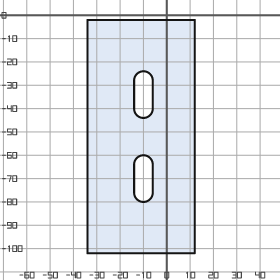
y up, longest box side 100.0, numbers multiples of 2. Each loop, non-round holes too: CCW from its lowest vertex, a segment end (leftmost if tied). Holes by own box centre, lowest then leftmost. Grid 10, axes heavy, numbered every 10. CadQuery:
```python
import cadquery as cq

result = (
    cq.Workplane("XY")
    .moveTo(-34.0, -102.0)
    .lineTo(12.0, -102.0)
    .lineTo(12.0, -2.0)
    .lineTo(-34.0, -2.0)
    .close()
    .moveTo(-14.0, -76.0)
    .threePointArc((-10.0, -80.0), (-6.0, -76.0))
    .lineTo(-6.0, -64.0)
    .threePointArc((-10.0, -60.0), (-14.0, -64.0))
    .close()
    .moveTo(-14.0, -40.0)
    .threePointArc((-10.0, -44.0), (-6.0, -40.0))
    .lineTo(-6.0, -28.0)
    .threePointArc((-10.0, -24.0), (-14.0, -28.0))
    .close()
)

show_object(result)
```